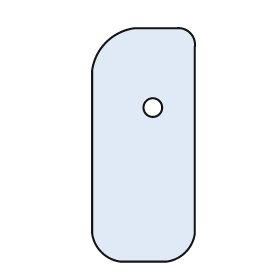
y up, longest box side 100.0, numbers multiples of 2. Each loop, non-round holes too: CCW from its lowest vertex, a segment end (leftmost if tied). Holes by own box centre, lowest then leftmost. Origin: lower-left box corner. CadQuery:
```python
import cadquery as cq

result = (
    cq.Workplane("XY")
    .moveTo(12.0, 0.0)
    .lineTo(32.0, 0.0)
    .threePointArc((40.0, 4.0), (44.0, 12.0))
    .lineTo(44.0, 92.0)
    .threePointArc((42.0, 98.0), (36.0, 100.0))
    .lineTo(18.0, 100.0)
    .threePointArc((6.0, 94.0), (0.0, 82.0))
    .lineTo(0.0, 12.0)
    .threePointArc((4.0, 4.0), (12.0, 0.0))
    .close()
    .moveTo(26.0, 66.0)
    .circle(4.0)
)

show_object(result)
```